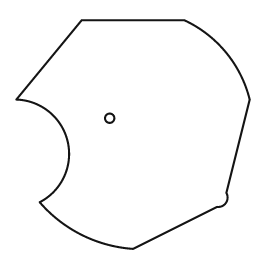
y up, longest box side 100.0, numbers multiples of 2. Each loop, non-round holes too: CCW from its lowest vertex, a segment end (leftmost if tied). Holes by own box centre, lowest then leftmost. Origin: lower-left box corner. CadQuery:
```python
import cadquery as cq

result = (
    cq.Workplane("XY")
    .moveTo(50.0, 0.0)
    .lineTo(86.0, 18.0)
    .threePointArc((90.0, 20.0), (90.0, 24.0))
    .lineTo(100.0, 64.0)
    .threePointArc((90.0, 84.0), (72.0, 98.0))
    .lineTo(28.0, 98.0)
    .lineTo(0.0, 64.0)
    .threePointArc((22.0, 46.0), (10.0, 20.0))
    .threePointArc((28.0, 6.0), (50.0, 0.0))
    .close()
    .moveTo(40.0, 56.0)
    .circle(2.0)
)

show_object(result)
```